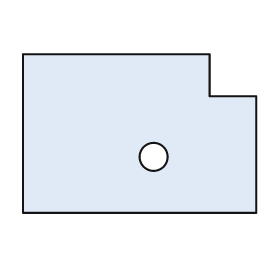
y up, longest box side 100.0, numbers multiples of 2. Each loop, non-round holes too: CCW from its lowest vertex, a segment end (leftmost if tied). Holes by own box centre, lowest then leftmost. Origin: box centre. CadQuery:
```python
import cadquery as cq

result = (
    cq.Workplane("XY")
    .moveTo(-50.0, -34.0)
    .lineTo(50.0, -34.0)
    .lineTo(50.0, 16.0)
    .lineTo(30.0, 16.0)
    .lineTo(30.0, 34.0)
    .lineTo(-50.0, 34.0)
    .close()
    .moveTo(6.0, -10.0)
    .circle(6.0)
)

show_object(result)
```